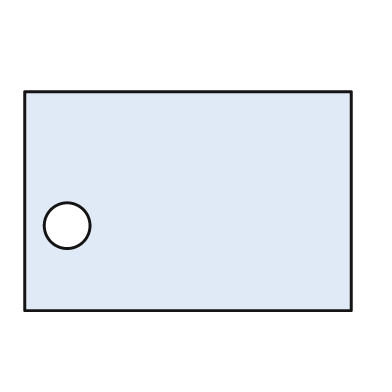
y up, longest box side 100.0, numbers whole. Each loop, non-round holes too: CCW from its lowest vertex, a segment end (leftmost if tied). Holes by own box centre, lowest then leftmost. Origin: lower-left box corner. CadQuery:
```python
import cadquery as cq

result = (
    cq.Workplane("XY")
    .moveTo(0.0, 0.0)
    .lineTo(100.0, 0.0)
    .lineTo(100.0, 67.0)
    .lineTo(0.0, 67.0)
    .close()
    .moveTo(13.0, 26.0)
    .circle(7.0)
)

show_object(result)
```